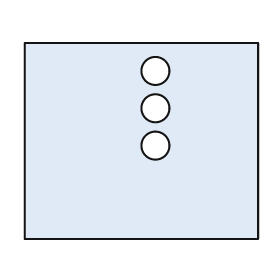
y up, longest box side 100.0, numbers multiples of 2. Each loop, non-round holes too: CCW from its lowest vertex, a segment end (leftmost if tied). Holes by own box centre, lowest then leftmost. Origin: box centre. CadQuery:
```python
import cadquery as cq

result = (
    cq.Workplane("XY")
    .moveTo(-50.0, -42.0)
    .lineTo(50.0, -42.0)
    .lineTo(50.0, 42.0)
    .lineTo(-50.0, 42.0)
    .close()
    .moveTo(6.0, -2.0)
    .circle(6.0)
    .moveTo(6.0, 14.0)
    .circle(6.0)
    .moveTo(6.0, 30.0)
    .circle(6.0)
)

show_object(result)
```